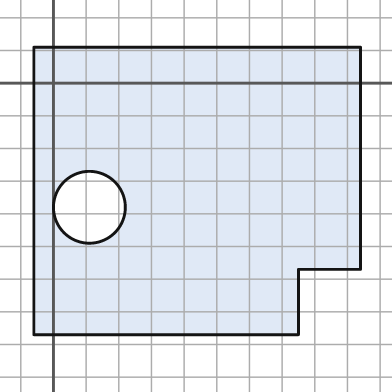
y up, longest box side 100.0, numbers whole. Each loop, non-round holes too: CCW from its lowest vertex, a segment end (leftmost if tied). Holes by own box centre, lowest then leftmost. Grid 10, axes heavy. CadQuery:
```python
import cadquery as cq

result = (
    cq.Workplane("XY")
    .moveTo(-6.0, -77.0)
    .lineTo(75.0, -77.0)
    .lineTo(75.0, -57.0)
    .lineTo(94.0, -57.0)
    .lineTo(94.0, 11.0)
    .lineTo(-6.0, 11.0)
    .close()
    .moveTo(11.0, -38.0)
    .circle(11.0)
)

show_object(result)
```